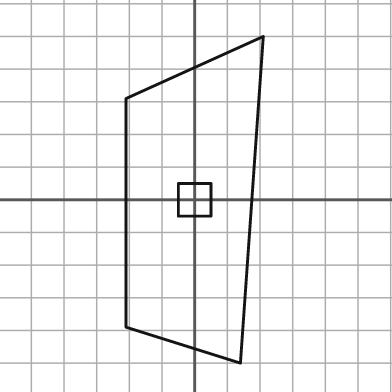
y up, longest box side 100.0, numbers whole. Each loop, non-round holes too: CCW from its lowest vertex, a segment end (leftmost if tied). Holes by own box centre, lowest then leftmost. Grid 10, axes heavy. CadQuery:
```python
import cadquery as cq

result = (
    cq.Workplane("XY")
    .moveTo(14.0, -50.0)
    .lineTo(21.0, 50.0)
    .lineTo(-21.0, 31.0)
    .lineTo(-21.0, -39.0)
    .close()
    .moveTo(-5.0, -5.0)
    .lineTo(5.0, -5.0)
    .lineTo(5.0, 5.0)
    .lineTo(-5.0, 5.0)
    .close()
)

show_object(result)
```